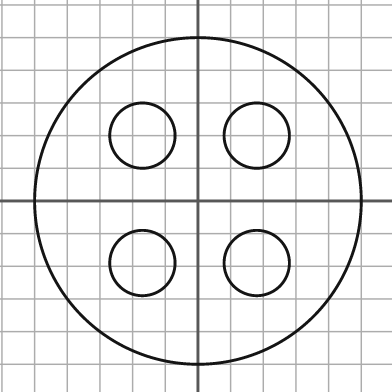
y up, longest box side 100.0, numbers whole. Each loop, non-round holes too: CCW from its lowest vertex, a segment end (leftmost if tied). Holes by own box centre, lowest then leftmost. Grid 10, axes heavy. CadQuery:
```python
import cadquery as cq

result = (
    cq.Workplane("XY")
    .moveTo(0.0, 0.0)
    .circle(50.0)
    .moveTo(-17.0, -19.0)
    .circle(10.0)
    .moveTo(18.0, -19.0)
    .circle(10.0)
    .moveTo(-17.0, 20.0)
    .circle(10.0)
    .moveTo(18.0, 20.0)
    .circle(10.0)
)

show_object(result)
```